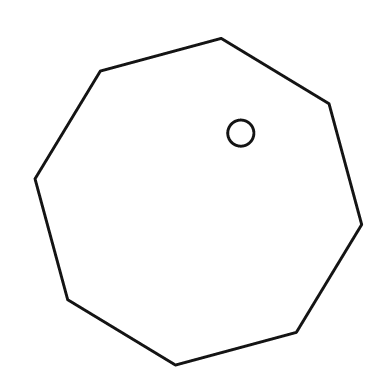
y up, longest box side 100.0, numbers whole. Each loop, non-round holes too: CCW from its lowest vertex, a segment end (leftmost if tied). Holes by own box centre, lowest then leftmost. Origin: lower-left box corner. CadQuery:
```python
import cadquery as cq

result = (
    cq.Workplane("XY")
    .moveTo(43.0, 0.0)
    .lineTo(80.0, 10.0)
    .lineTo(100.0, 43.0)
    .lineTo(90.0, 80.0)
    .lineTo(57.0, 100.0)
    .lineTo(20.0, 90.0)
    .lineTo(0.0, 57.0)
    .lineTo(10.0, 20.0)
    .close()
    .moveTo(63.0, 71.0)
    .circle(4.0)
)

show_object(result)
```